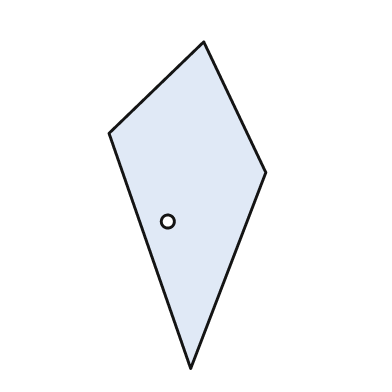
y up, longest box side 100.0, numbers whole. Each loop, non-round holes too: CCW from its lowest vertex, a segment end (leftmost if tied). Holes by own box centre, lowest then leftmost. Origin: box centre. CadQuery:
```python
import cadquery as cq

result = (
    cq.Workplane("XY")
    .moveTo(1.0, -50.0)
    .lineTo(24.0, 10.0)
    .lineTo(5.0, 50.0)
    .lineTo(-24.0, 22.0)
    .close()
    .moveTo(-6.0, -5.0)
    .circle(2.0)
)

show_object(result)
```